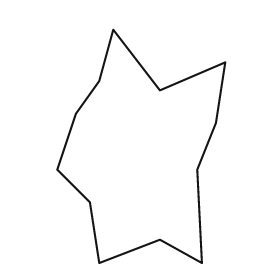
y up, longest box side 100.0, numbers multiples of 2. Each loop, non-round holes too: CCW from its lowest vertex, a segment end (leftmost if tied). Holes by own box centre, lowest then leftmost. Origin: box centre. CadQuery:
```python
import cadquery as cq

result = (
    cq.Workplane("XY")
    .moveTo(-18.0, -50.0)
    .lineTo(8.0, -40.0)
    .lineTo(26.0, -50.0)
    .lineTo(24.0, -10.0)
    .lineTo(32.0, 10.0)
    .lineTo(36.0, 36.0)
    .lineTo(8.0, 24.0)
    .lineTo(-12.0, 50.0)
    .lineTo(-18.0, 28.0)
    .lineTo(-28.0, 14.0)
    .lineTo(-36.0, -10.0)
    .lineTo(-22.0, -24.0)
    .close()
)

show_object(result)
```